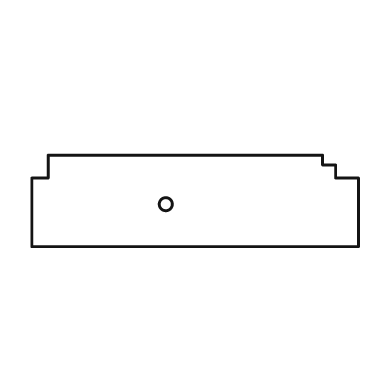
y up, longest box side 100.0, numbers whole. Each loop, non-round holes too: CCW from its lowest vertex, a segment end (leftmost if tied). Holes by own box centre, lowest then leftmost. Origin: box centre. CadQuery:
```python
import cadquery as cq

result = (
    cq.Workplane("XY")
    .moveTo(-50.0, -14.0)
    .lineTo(50.0, -14.0)
    .lineTo(50.0, 7.0)
    .lineTo(43.0, 7.0)
    .lineTo(43.0, 11.0)
    .lineTo(39.0, 11.0)
    .lineTo(39.0, 14.0)
    .lineTo(-45.0, 14.0)
    .lineTo(-45.0, 7.0)
    .lineTo(-50.0, 7.0)
    .close()
    .moveTo(-9.0, -1.0)
    .circle(2.0)
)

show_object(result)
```